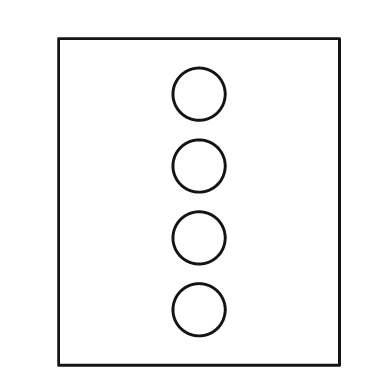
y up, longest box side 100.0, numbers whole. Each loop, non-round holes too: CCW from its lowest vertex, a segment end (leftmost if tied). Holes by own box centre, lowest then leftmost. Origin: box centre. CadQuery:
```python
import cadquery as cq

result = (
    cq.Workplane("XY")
    .moveTo(-43.0, -50.0)
    .lineTo(43.0, -50.0)
    .lineTo(43.0, 50.0)
    .lineTo(-43.0, 50.0)
    .close()
    .moveTo(0.0, -33.0)
    .circle(8.0)
    .moveTo(0.0, -11.0)
    .circle(8.0)
    .moveTo(0.0, 11.0)
    .circle(8.0)
    .moveTo(0.0, 33.0)
    .circle(8.0)
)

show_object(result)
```